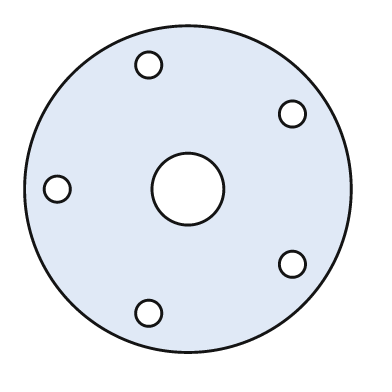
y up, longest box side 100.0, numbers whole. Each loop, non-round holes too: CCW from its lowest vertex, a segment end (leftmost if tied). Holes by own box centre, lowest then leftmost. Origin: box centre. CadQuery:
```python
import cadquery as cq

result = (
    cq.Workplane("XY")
    .moveTo(0.0, 0.0)
    .circle(50.0)
    .moveTo(-12.0, -38.0)
    .circle(4.0)
    .moveTo(32.0, -23.0)
    .circle(4.0)
    .moveTo(-40.0, 0.0)
    .circle(4.0)
    .moveTo(0.0, 0.0)
    .circle(11.0)
    .moveTo(32.0, 23.0)
    .circle(4.0)
    .moveTo(-12.0, 38.0)
    .circle(4.0)
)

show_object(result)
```